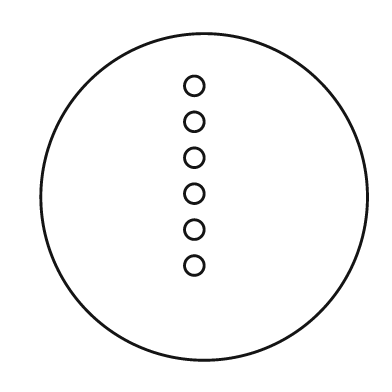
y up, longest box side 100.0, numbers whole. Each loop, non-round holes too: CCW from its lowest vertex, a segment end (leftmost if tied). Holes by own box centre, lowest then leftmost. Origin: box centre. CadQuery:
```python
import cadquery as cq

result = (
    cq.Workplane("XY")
    .moveTo(0.0, 0.0)
    .circle(50.0)
    .moveTo(-3.0, -21.0)
    .circle(3.0)
    .moveTo(-3.0, -10.0)
    .circle(3.0)
    .moveTo(-3.0, 1.0)
    .circle(3.0)
    .moveTo(-3.0, 12.0)
    .circle(3.0)
    .moveTo(-3.0, 23.0)
    .circle(3.0)
    .moveTo(-3.0, 34.0)
    .circle(3.0)
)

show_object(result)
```